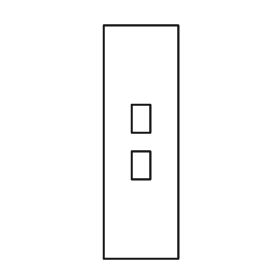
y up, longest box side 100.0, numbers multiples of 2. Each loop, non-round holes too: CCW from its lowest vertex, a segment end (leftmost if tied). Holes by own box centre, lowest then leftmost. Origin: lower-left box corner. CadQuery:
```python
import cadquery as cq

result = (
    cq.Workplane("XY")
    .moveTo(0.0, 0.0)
    .lineTo(32.0, 0.0)
    .lineTo(32.0, 100.0)
    .lineTo(0.0, 100.0)
    .close()
    .moveTo(12.0, 34.0)
    .lineTo(20.0, 34.0)
    .lineTo(20.0, 46.0)
    .lineTo(12.0, 46.0)
    .close()
    .moveTo(12.0, 54.0)
    .lineTo(20.0, 54.0)
    .lineTo(20.0, 66.0)
    .lineTo(12.0, 66.0)
    .close()
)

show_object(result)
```